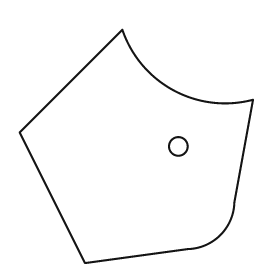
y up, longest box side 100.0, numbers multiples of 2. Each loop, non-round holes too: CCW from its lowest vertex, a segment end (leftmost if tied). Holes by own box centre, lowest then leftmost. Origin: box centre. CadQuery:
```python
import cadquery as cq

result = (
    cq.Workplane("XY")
    .moveTo(-22.0, -50.0)
    .lineTo(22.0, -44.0)
    .threePointArc((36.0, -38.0), (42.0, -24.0))
    .lineTo(50.0, 20.0)
    .threePointArc((16.0, 24.0), (-6.0, 50.0))
    .lineTo(-50.0, 6.0)
    .close()
    .moveTo(18.0, 0.0)
    .circle(4.0)
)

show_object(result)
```